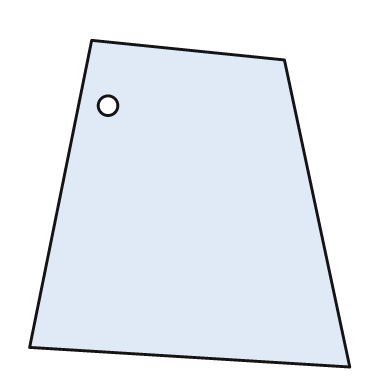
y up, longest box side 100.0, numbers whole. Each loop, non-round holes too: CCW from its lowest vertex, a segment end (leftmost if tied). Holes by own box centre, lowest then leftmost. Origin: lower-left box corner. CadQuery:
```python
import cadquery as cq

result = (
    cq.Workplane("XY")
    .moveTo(98.0, 0.0)
    .lineTo(78.0, 94.0)
    .lineTo(19.0, 100.0)
    .lineTo(0.0, 6.0)
    .close()
    .moveTo(24.0, 80.0)
    .circle(3.0)
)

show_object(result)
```